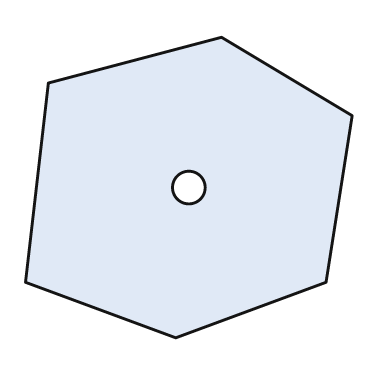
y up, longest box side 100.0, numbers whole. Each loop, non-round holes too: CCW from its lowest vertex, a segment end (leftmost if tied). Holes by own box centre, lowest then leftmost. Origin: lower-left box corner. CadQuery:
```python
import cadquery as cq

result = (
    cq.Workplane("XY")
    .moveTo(46.0, 0.0)
    .lineTo(92.0, 17.0)
    .lineTo(100.0, 68.0)
    .lineTo(60.0, 92.0)
    .lineTo(7.0, 78.0)
    .lineTo(0.0, 17.0)
    .close()
    .moveTo(50.0, 46.0)
    .circle(5.0)
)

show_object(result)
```